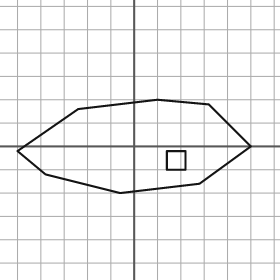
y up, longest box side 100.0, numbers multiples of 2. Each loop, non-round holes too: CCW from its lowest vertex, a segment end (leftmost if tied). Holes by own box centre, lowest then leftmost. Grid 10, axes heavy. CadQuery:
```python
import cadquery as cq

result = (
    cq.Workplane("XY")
    .moveTo(-6.0, -20.0)
    .lineTo(28.0, -16.0)
    .lineTo(50.0, 0.0)
    .lineTo(32.0, 18.0)
    .lineTo(10.0, 20.0)
    .lineTo(-24.0, 16.0)
    .lineTo(-50.0, -2.0)
    .lineTo(-38.0, -12.0)
    .close()
    .moveTo(14.0, -10.0)
    .lineTo(22.0, -10.0)
    .lineTo(22.0, -2.0)
    .lineTo(14.0, -2.0)
    .close()
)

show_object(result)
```